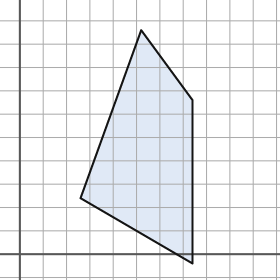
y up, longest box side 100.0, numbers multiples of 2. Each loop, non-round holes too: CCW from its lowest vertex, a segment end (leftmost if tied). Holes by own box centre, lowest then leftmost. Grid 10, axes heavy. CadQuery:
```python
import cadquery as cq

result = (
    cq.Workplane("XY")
    .moveTo(74.0, -4.0)
    .lineTo(74.0, 66.0)
    .lineTo(52.0, 96.0)
    .lineTo(26.0, 24.0)
    .close()
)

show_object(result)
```